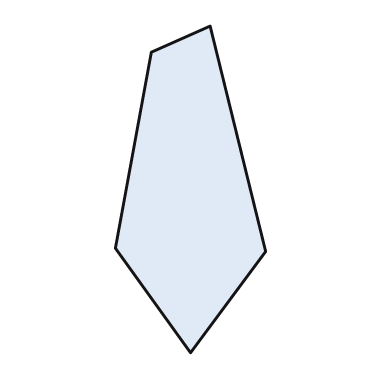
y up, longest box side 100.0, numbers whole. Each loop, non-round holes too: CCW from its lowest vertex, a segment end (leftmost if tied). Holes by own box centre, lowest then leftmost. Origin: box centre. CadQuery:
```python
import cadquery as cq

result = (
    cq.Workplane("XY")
    .moveTo(0.0, -50.0)
    .lineTo(23.0, -19.0)
    .lineTo(6.0, 50.0)
    .lineTo(-12.0, 42.0)
    .lineTo(-23.0, -18.0)
    .close()
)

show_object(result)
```